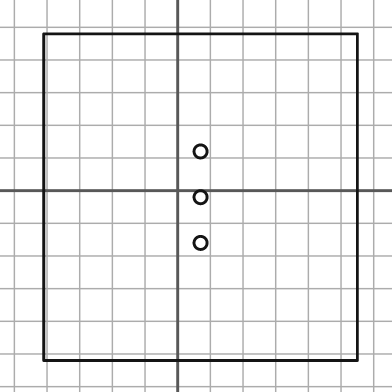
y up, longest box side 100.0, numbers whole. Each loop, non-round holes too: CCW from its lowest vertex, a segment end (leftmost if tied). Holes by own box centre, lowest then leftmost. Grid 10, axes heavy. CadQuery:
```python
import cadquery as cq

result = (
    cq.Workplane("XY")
    .moveTo(-41.0, -52.0)
    .lineTo(55.0, -52.0)
    .lineTo(55.0, 48.0)
    .lineTo(-41.0, 48.0)
    .close()
    .moveTo(7.0, -16.0)
    .circle(2.0)
    .moveTo(7.0, -2.0)
    .circle(2.0)
    .moveTo(7.0, 12.0)
    .circle(2.0)
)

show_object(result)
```